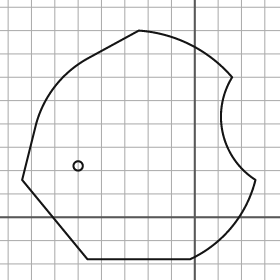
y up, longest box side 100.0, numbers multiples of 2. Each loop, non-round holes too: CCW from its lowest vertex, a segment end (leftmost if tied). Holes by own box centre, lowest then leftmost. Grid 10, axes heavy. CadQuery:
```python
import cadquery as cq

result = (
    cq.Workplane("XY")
    .moveTo(-46.0, -18.0)
    .lineTo(-2.0, -18.0)
    .threePointArc((16.0, -4.0), (26.0, 16.0))
    .threePointArc((12.0, 36.0), (16.0, 60.0))
    .threePointArc((-2.0, 74.0), (-24.0, 80.0))
    .lineTo(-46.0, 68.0)
    .threePointArc((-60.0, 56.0), (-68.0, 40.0))
    .lineTo(-74.0, 16.0)
    .close()
    .moveTo(-50.0, 22.0)
    .circle(2.0)
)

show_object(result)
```